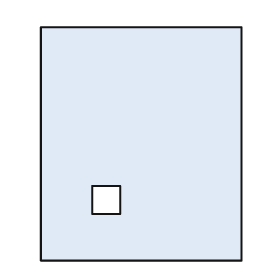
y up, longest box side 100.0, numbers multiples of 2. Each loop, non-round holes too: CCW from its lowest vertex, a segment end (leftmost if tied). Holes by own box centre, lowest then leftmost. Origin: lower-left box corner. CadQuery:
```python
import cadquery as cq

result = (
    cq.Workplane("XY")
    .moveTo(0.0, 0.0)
    .lineTo(86.0, 0.0)
    .lineTo(86.0, 100.0)
    .lineTo(0.0, 100.0)
    .close()
    .moveTo(22.0, 20.0)
    .lineTo(34.0, 20.0)
    .lineTo(34.0, 32.0)
    .lineTo(22.0, 32.0)
    .close()
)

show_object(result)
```